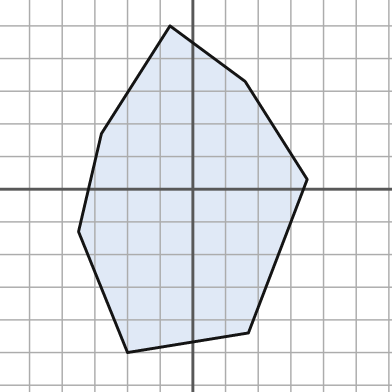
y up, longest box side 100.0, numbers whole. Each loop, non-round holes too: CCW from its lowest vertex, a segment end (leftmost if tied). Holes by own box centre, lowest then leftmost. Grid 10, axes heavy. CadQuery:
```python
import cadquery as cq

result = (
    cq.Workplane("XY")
    .moveTo(-20.0, -50.0)
    .lineTo(17.0, -44.0)
    .lineTo(35.0, 3.0)
    .lineTo(16.0, 33.0)
    .lineTo(-7.0, 50.0)
    .lineTo(-28.0, 17.0)
    .lineTo(-35.0, -13.0)
    .close()
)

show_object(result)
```